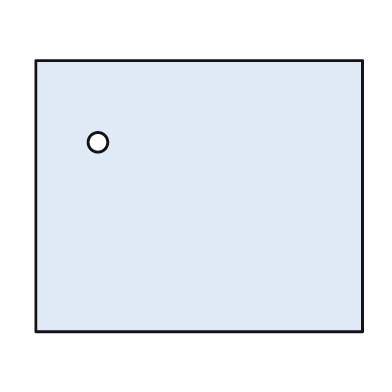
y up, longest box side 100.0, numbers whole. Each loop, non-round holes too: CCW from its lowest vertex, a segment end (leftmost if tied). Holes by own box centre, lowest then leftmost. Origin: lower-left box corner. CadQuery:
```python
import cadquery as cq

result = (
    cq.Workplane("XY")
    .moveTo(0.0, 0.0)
    .lineTo(100.0, 0.0)
    .lineTo(100.0, 83.0)
    .lineTo(0.0, 83.0)
    .close()
    .moveTo(19.0, 58.0)
    .circle(3.0)
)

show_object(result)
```